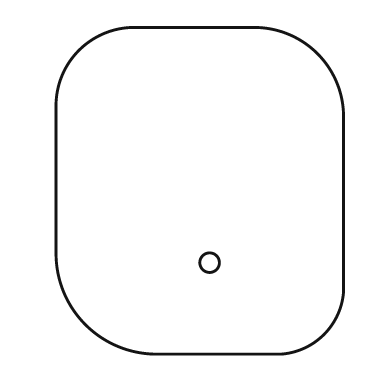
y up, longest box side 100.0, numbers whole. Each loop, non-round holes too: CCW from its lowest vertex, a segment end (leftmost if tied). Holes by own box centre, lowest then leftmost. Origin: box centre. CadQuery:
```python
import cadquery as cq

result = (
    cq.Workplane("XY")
    .moveTo(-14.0, -50.0)
    .lineTo(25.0, -50.0)
    .threePointArc((38.0, -44.0), (44.0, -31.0))
    .lineTo(44.0, 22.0)
    .threePointArc((36.0, 42.0), (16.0, 50.0))
    .lineTo(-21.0, 50.0)
    .threePointArc((-37.0, 43.0), (-44.0, 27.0))
    .lineTo(-44.0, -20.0)
    .threePointArc((-35.0, -41.0), (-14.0, -50.0))
    .close()
    .moveTo(3.0, -22.0)
    .circle(3.0)
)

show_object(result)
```